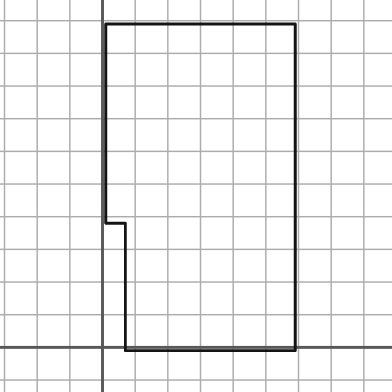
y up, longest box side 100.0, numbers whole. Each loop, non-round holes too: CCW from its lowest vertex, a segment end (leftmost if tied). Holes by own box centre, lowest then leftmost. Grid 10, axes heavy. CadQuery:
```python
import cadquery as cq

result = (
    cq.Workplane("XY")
    .moveTo(7.0, -1.0)
    .lineTo(59.0, -1.0)
    .lineTo(59.0, 99.0)
    .lineTo(1.0, 99.0)
    .lineTo(1.0, 38.0)
    .lineTo(7.0, 38.0)
    .close()
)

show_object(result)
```